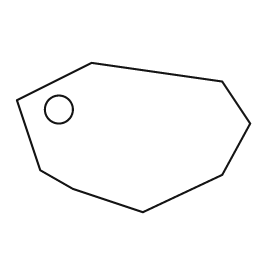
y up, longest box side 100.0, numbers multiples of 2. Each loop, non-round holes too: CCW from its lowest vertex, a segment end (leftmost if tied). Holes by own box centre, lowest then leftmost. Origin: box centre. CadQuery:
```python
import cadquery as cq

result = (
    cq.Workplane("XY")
    .moveTo(4.0, -32.0)
    .lineTo(38.0, -16.0)
    .lineTo(50.0, 6.0)
    .lineTo(38.0, 24.0)
    .lineTo(-18.0, 32.0)
    .lineTo(-50.0, 16.0)
    .lineTo(-40.0, -14.0)
    .lineTo(-26.0, -22.0)
    .close()
    .moveTo(-32.0, 12.0)
    .circle(6.0)
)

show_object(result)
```